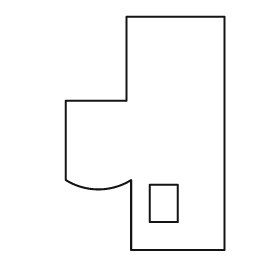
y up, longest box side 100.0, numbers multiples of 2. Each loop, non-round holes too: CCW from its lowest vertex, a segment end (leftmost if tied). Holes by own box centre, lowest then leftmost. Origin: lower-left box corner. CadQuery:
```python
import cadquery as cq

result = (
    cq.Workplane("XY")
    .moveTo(28.0, 0.0)
    .lineTo(68.0, 0.0)
    .lineTo(68.0, 100.0)
    .lineTo(26.0, 100.0)
    .lineTo(26.0, 64.0)
    .lineTo(0.0, 64.0)
    .lineTo(0.0, 30.0)
    .threePointArc((14.0, 26.0), (28.0, 30.0))
    .close()
    .moveTo(36.0, 12.0)
    .lineTo(48.0, 12.0)
    .lineTo(48.0, 28.0)
    .lineTo(36.0, 28.0)
    .close()
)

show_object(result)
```